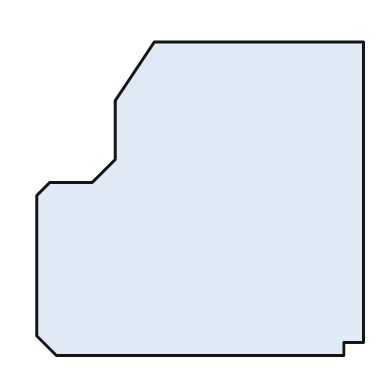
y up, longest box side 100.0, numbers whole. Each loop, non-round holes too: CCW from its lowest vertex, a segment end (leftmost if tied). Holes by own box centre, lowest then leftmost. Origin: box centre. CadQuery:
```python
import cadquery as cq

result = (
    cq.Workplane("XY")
    .moveTo(-44.0, -48.0)
    .lineTo(44.0, -48.0)
    .lineTo(44.0, -44.0)
    .lineTo(50.0, -44.0)
    .lineTo(50.0, 48.0)
    .lineTo(-14.0, 48.0)
    .lineTo(-26.0, 30.0)
    .lineTo(-26.0, 12.0)
    .lineTo(-33.0, 5.0)
    .lineTo(-46.0, 5.0)
    .lineTo(-50.0, 1.0)
    .lineTo(-50.0, -42.0)
    .close()
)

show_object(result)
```